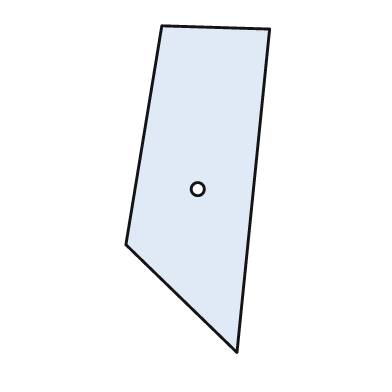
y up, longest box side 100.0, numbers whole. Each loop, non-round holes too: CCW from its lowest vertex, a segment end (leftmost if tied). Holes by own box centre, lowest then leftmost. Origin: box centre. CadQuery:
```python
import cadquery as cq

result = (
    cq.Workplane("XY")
    .moveTo(12.0, -50.0)
    .lineTo(22.0, 49.0)
    .lineTo(-11.0, 50.0)
    .lineTo(-22.0, -17.0)
    .close()
    .moveTo(0.0, 0.0)
    .circle(2.0)
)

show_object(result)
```